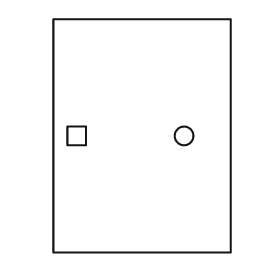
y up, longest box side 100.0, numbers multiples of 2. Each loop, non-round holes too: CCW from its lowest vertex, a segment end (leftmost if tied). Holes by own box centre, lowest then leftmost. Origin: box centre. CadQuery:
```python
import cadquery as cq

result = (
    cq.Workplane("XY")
    .moveTo(-38.0, -50.0)
    .lineTo(38.0, -50.0)
    .lineTo(38.0, 50.0)
    .lineTo(-38.0, 50.0)
    .close()
    .moveTo(-32.0, -4.0)
    .lineTo(-24.0, -4.0)
    .lineTo(-24.0, 4.0)
    .lineTo(-32.0, 4.0)
    .close()
    .moveTo(18.0, 0.0)
    .circle(4.0)
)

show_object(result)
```